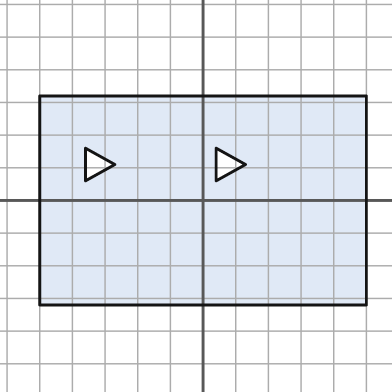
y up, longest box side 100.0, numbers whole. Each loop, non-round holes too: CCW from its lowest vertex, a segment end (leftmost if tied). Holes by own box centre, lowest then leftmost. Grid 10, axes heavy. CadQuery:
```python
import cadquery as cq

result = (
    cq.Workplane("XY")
    .moveTo(-50.0, -32.0)
    .lineTo(50.0, -32.0)
    .lineTo(50.0, 32.0)
    .lineTo(-50.0, 32.0)
    .close()
    .moveTo(-36.0, 6.0)
    .lineTo(-27.0, 11.0)
    .lineTo(-36.0, 16.0)
    .close()
    .moveTo(4.0, 6.0)
    .lineTo(13.0, 11.0)
    .lineTo(4.0, 16.0)
    .close()
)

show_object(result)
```